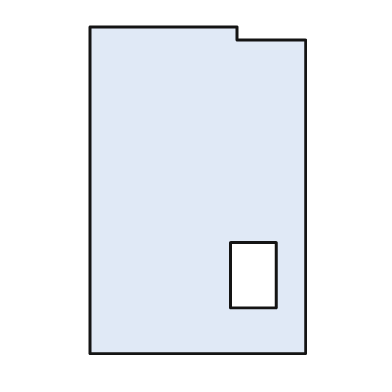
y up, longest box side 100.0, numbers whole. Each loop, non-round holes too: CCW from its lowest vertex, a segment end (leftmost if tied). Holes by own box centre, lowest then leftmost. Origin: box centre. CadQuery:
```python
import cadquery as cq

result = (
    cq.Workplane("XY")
    .moveTo(-33.0, -50.0)
    .lineTo(33.0, -50.0)
    .lineTo(33.0, 46.0)
    .lineTo(12.0, 46.0)
    .lineTo(12.0, 50.0)
    .lineTo(-33.0, 50.0)
    .close()
    .moveTo(10.0, -36.0)
    .lineTo(24.0, -36.0)
    .lineTo(24.0, -16.0)
    .lineTo(10.0, -16.0)
    .close()
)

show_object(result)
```